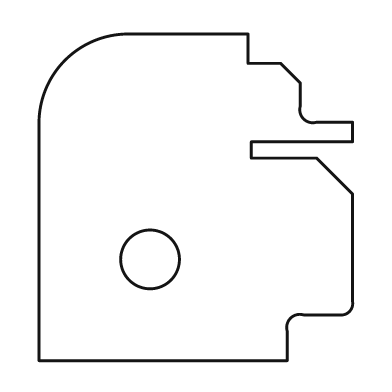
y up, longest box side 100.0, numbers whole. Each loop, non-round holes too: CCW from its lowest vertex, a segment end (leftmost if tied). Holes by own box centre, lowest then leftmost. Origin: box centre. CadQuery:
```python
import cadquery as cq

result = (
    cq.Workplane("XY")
    .moveTo(-48.0, -50.0)
    .lineTo(28.0, -50.0)
    .lineTo(28.0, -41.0)
    .threePointArc((29.0, -37.0), (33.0, -36.0))
    .lineTo(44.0, -36.0)
    .threePointArc((47.0, -35.0), (48.0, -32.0))
    .lineTo(48.0, 1.0)
    .lineTo(37.0, 12.0)
    .lineTo(17.0, 12.0)
    .lineTo(17.0, 17.0)
    .lineTo(48.0, 17.0)
    .lineTo(48.0, 23.0)
    .lineTo(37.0, 23.0)
    .threePointArc((33.0, 24.0), (32.0, 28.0))
    .lineTo(32.0, 35.0)
    .lineTo(26.0, 41.0)
    .lineTo(16.0, 41.0)
    .lineTo(16.0, 50.0)
    .lineTo(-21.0, 50.0)
    .threePointArc((-40.0, 42.0), (-48.0, 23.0))
    .close()
    .moveTo(-14.0, -19.0)
    .circle(9.0)
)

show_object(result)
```